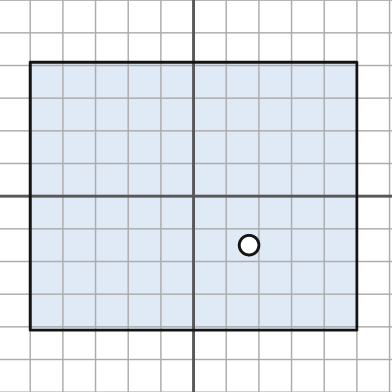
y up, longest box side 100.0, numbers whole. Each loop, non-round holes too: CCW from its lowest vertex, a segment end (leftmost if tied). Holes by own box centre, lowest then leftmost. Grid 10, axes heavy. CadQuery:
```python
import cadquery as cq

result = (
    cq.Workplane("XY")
    .moveTo(-50.0, -41.0)
    .lineTo(50.0, -41.0)
    .lineTo(50.0, 41.0)
    .lineTo(-50.0, 41.0)
    .close()
    .moveTo(17.0, -15.0)
    .circle(3.0)
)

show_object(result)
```